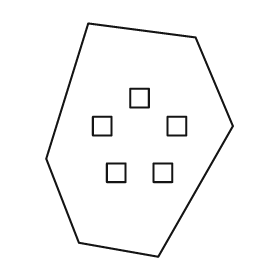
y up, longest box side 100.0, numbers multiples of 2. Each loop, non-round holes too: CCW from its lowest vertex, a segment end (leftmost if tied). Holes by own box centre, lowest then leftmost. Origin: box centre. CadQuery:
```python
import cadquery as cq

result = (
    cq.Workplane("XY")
    .moveTo(8.0, -50.0)
    .lineTo(40.0, 6.0)
    .lineTo(24.0, 44.0)
    .lineTo(-22.0, 50.0)
    .lineTo(-40.0, -8.0)
    .lineTo(-26.0, -44.0)
    .close()
    .moveTo(-14.0, -18.0)
    .lineTo(-6.0, -18.0)
    .lineTo(-6.0, -10.0)
    .lineTo(-14.0, -10.0)
    .close()
    .moveTo(6.0, -18.0)
    .lineTo(14.0, -18.0)
    .lineTo(14.0, -10.0)
    .lineTo(6.0, -10.0)
    .close()
    .moveTo(-20.0, 2.0)
    .lineTo(-12.0, 2.0)
    .lineTo(-12.0, 10.0)
    .lineTo(-20.0, 10.0)
    .close()
    .moveTo(12.0, 2.0)
    .lineTo(20.0, 2.0)
    .lineTo(20.0, 10.0)
    .lineTo(12.0, 10.0)
    .close()
    .moveTo(-4.0, 14.0)
    .lineTo(4.0, 14.0)
    .lineTo(4.0, 22.0)
    .lineTo(-4.0, 22.0)
    .close()
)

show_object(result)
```